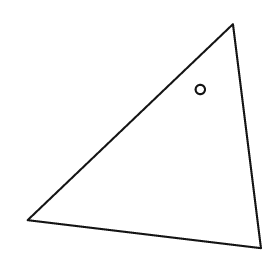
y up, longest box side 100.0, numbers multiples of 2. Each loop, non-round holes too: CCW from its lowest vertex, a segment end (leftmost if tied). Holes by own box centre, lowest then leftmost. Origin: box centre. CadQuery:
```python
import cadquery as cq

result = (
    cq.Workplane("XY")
    .moveTo(50.0, -48.0)
    .lineTo(38.0, 48.0)
    .lineTo(-50.0, -36.0)
    .close()
    .moveTo(24.0, 20.0)
    .circle(2.0)
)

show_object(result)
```